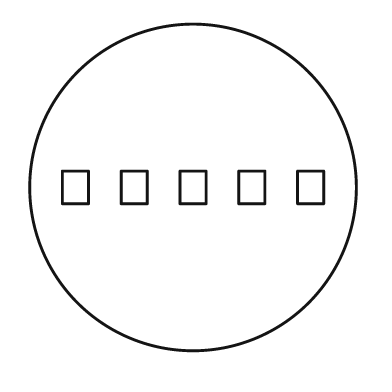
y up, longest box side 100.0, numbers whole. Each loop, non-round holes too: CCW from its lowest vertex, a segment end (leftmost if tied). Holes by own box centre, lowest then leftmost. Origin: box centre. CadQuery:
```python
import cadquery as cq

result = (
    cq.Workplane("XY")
    .moveTo(0.0, 0.0)
    .circle(50.0)
    .moveTo(-40.0, -5.0)
    .lineTo(-32.0, -5.0)
    .lineTo(-32.0, 5.0)
    .lineTo(-40.0, 5.0)
    .close()
    .moveTo(-22.0, -5.0)
    .lineTo(-14.0, -5.0)
    .lineTo(-14.0, 5.0)
    .lineTo(-22.0, 5.0)
    .close()
    .moveTo(-4.0, -5.0)
    .lineTo(4.0, -5.0)
    .lineTo(4.0, 5.0)
    .lineTo(-4.0, 5.0)
    .close()
    .moveTo(14.0, -5.0)
    .lineTo(22.0, -5.0)
    .lineTo(22.0, 5.0)
    .lineTo(14.0, 5.0)
    .close()
    .moveTo(32.0, -5.0)
    .lineTo(40.0, -5.0)
    .lineTo(40.0, 5.0)
    .lineTo(32.0, 5.0)
    .close()
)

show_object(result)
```